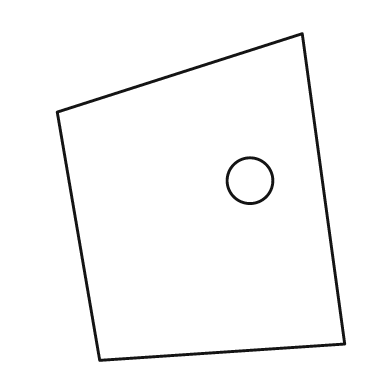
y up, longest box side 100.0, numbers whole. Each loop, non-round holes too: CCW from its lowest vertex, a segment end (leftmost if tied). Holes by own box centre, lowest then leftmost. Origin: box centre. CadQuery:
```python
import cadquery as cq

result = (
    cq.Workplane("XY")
    .moveTo(-31.0, -50.0)
    .lineTo(44.0, -45.0)
    .lineTo(31.0, 50.0)
    .lineTo(-44.0, 26.0)
    .close()
    .moveTo(15.0, 5.0)
    .circle(7.0)
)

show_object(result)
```